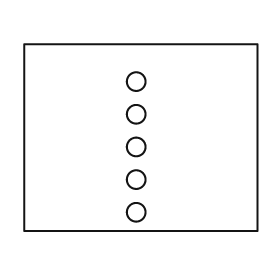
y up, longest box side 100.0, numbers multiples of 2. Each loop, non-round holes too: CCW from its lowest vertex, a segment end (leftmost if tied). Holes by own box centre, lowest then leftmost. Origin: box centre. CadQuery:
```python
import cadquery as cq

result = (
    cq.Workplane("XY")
    .moveTo(-50.0, -40.0)
    .lineTo(50.0, -40.0)
    .lineTo(50.0, 40.0)
    .lineTo(-50.0, 40.0)
    .close()
    .moveTo(-2.0, -32.0)
    .circle(4.0)
    .moveTo(-2.0, -18.0)
    .circle(4.0)
    .moveTo(-2.0, -4.0)
    .circle(4.0)
    .moveTo(-2.0, 10.0)
    .circle(4.0)
    .moveTo(-2.0, 24.0)
    .circle(4.0)
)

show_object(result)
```